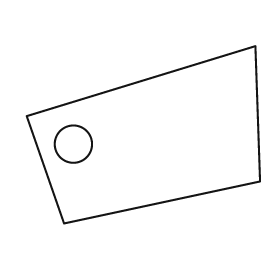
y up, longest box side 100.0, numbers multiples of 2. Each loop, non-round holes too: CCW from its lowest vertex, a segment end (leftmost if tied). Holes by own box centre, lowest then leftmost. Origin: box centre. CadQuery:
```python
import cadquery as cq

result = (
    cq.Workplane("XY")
    .moveTo(-34.0, -38.0)
    .lineTo(50.0, -20.0)
    .lineTo(48.0, 38.0)
    .lineTo(-50.0, 8.0)
    .close()
    .moveTo(-30.0, -4.0)
    .circle(8.0)
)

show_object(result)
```